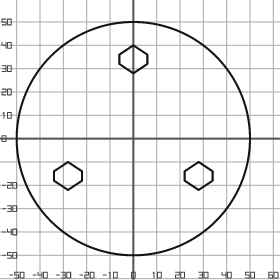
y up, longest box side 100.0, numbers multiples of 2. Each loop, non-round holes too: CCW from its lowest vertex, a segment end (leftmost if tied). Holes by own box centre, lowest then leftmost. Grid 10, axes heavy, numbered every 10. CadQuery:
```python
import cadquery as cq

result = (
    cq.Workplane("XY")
    .moveTo(0.0, 0.0)
    .circle(50.0)
    .moveTo(-28.0, -22.0)
    .lineTo(-22.0, -18.0)
    .lineTo(-22.0, -14.0)
    .lineTo(-28.0, -10.0)
    .lineTo(-34.0, -14.0)
    .lineTo(-34.0, -18.0)
    .close()
    .moveTo(28.0, -22.0)
    .lineTo(34.0, -18.0)
    .lineTo(34.0, -14.0)
    .lineTo(28.0, -10.0)
    .lineTo(22.0, -14.0)
    .lineTo(22.0, -18.0)
    .close()
    .moveTo(0.0, 28.0)
    .lineTo(6.0, 32.0)
    .lineTo(6.0, 36.0)
    .lineTo(0.0, 40.0)
    .lineTo(-6.0, 36.0)
    .lineTo(-6.0, 32.0)
    .close()
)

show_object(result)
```